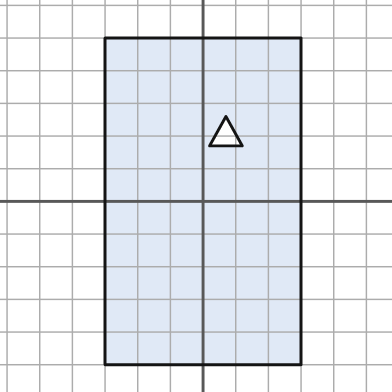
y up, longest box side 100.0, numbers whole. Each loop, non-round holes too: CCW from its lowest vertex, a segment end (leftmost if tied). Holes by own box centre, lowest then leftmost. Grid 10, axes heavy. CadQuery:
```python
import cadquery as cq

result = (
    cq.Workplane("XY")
    .moveTo(-30.0, -50.0)
    .lineTo(30.0, -50.0)
    .lineTo(30.0, 50.0)
    .lineTo(-30.0, 50.0)
    .close()
    .moveTo(2.0, 17.0)
    .lineTo(12.0, 17.0)
    .lineTo(7.0, 26.0)
    .close()
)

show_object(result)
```